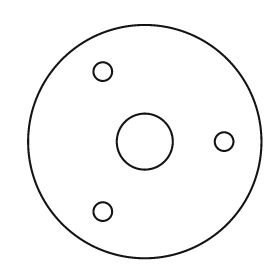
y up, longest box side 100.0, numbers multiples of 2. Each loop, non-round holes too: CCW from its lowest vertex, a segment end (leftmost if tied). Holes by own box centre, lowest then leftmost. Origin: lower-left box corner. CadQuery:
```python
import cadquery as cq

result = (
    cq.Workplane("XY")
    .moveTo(50.0, 50.0)
    .circle(50.0)
    .moveTo(32.0, 20.0)
    .circle(4.0)
    .moveTo(50.0, 50.0)
    .circle(12.0)
    .moveTo(84.0, 50.0)
    .circle(4.0)
    .moveTo(32.0, 80.0)
    .circle(4.0)
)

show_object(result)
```